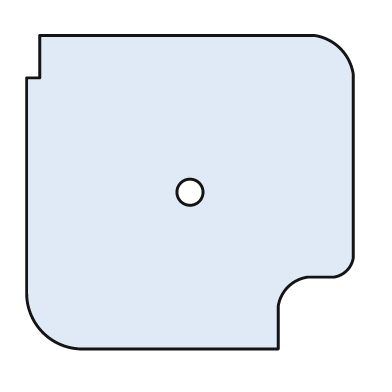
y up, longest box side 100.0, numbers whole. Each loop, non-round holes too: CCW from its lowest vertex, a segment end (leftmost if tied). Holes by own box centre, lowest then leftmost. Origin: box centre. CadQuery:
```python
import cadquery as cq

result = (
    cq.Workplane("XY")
    .moveTo(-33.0, -48.0)
    .lineTo(27.0, -48.0)
    .lineTo(27.0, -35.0)
    .threePointArc((30.0, -29.0), (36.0, -26.0))
    .lineTo(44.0, -26.0)
    .threePointArc((48.0, -24.0), (50.0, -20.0))
    .lineTo(50.0, 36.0)
    .threePointArc((46.0, 44.0), (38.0, 48.0))
    .lineTo(-46.0, 48.0)
    .lineTo(-46.0, 35.0)
    .lineTo(-50.0, 35.0)
    .lineTo(-50.0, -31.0)
    .threePointArc((-45.0, -43.0), (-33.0, -48.0))
    .close()
    .moveTo(0.0, 0.0)
    .circle(4.0)
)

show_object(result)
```